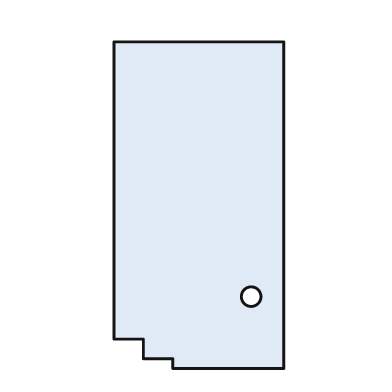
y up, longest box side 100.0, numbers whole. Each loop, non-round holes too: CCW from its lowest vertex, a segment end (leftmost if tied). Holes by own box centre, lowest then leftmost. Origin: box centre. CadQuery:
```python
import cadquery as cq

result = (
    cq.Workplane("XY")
    .moveTo(-8.0, -50.0)
    .lineTo(26.0, -50.0)
    .lineTo(26.0, 50.0)
    .lineTo(-26.0, 50.0)
    .lineTo(-26.0, -41.0)
    .lineTo(-17.0, -41.0)
    .lineTo(-17.0, -47.0)
    .lineTo(-8.0, -47.0)
    .close()
    .moveTo(16.0, -28.0)
    .circle(3.0)
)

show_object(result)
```